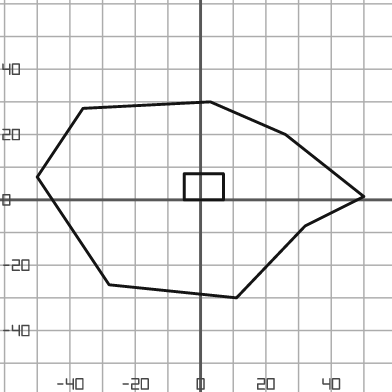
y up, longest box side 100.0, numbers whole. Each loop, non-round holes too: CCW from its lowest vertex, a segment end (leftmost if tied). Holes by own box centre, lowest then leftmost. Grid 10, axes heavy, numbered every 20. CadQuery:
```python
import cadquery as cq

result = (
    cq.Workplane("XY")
    .moveTo(11.0, -30.0)
    .lineTo(32.0, -8.0)
    .lineTo(50.0, 1.0)
    .lineTo(26.0, 20.0)
    .lineTo(3.0, 30.0)
    .lineTo(-36.0, 28.0)
    .lineTo(-50.0, 7.0)
    .lineTo(-28.0, -26.0)
    .close()
    .moveTo(-5.0, 0.0)
    .lineTo(7.0, 0.0)
    .lineTo(7.0, 8.0)
    .lineTo(-5.0, 8.0)
    .close()
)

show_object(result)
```